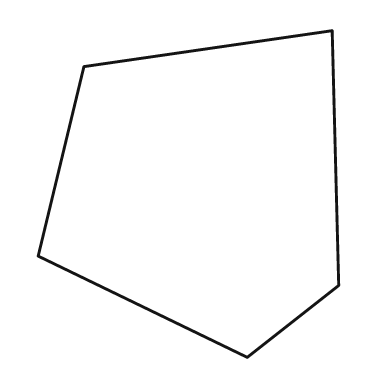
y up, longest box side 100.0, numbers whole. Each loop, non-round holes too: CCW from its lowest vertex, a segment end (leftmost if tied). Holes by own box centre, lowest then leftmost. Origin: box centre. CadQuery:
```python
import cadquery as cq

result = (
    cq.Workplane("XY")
    .moveTo(18.0, -50.0)
    .lineTo(46.0, -28.0)
    .lineTo(44.0, 50.0)
    .lineTo(-32.0, 39.0)
    .lineTo(-46.0, -19.0)
    .close()
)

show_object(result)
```